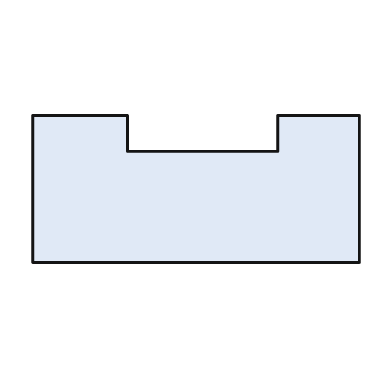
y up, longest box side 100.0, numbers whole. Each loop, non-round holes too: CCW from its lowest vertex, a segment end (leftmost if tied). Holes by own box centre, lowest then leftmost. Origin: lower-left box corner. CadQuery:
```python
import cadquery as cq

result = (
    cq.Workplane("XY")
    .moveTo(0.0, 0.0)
    .lineTo(100.0, 0.0)
    .lineTo(100.0, 45.0)
    .lineTo(75.0, 45.0)
    .lineTo(75.0, 34.0)
    .lineTo(29.0, 34.0)
    .lineTo(29.0, 45.0)
    .lineTo(0.0, 45.0)
    .close()
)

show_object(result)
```